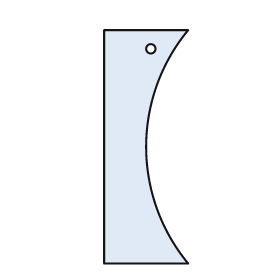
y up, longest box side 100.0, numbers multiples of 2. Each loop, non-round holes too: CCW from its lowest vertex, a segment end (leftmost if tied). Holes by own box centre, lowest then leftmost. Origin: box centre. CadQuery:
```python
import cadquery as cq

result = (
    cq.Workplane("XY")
    .moveTo(-18.0, -50.0)
    .lineTo(18.0, -50.0)
    .threePointArc((0.0, 0.0), (18.0, 50.0))
    .lineTo(-18.0, 50.0)
    .close()
    .moveTo(2.0, 42.0)
    .circle(2.0)
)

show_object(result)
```